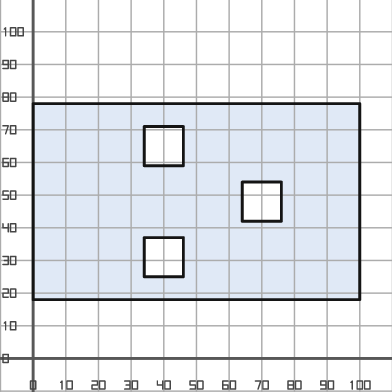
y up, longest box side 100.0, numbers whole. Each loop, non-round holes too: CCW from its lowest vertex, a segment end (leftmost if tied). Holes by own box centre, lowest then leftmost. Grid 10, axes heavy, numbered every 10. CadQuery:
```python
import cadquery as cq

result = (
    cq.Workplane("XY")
    .moveTo(0.0, 18.0)
    .lineTo(100.0, 18.0)
    .lineTo(100.0, 78.0)
    .lineTo(0.0, 78.0)
    .close()
    .moveTo(34.0, 25.0)
    .lineTo(46.0, 25.0)
    .lineTo(46.0, 37.0)
    .lineTo(34.0, 37.0)
    .close()
    .moveTo(64.0, 42.0)
    .lineTo(76.0, 42.0)
    .lineTo(76.0, 54.0)
    .lineTo(64.0, 54.0)
    .close()
    .moveTo(34.0, 59.0)
    .lineTo(46.0, 59.0)
    .lineTo(46.0, 71.0)
    .lineTo(34.0, 71.0)
    .close()
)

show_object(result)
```